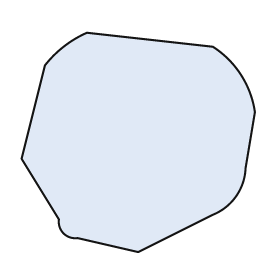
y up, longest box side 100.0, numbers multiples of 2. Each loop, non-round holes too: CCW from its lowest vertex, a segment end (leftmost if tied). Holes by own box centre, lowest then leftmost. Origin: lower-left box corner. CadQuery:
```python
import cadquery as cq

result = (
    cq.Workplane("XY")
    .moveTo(50.0, 0.0)
    .lineTo(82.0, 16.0)
    .threePointArc((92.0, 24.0), (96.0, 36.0))
    .lineTo(100.0, 60.0)
    .threePointArc((94.0, 76.0), (82.0, 88.0))
    .lineTo(28.0, 94.0)
    .threePointArc((18.0, 88.0), (10.0, 80.0))
    .lineTo(0.0, 40.0)
    .lineTo(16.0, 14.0)
    .threePointArc((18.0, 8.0), (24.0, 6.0))
    .close()
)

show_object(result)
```